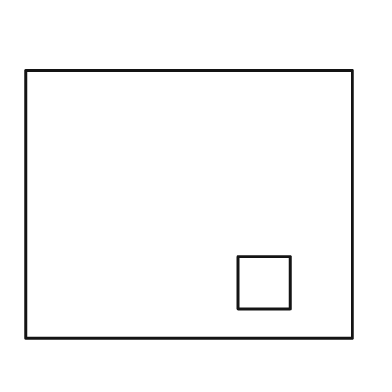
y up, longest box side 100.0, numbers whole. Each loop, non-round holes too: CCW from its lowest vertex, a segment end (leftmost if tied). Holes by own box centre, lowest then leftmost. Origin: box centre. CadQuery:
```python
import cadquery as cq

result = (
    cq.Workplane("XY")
    .moveTo(-50.0, -41.0)
    .lineTo(50.0, -41.0)
    .lineTo(50.0, 41.0)
    .lineTo(-50.0, 41.0)
    .close()
    .moveTo(15.0, -32.0)
    .lineTo(31.0, -32.0)
    .lineTo(31.0, -16.0)
    .lineTo(15.0, -16.0)
    .close()
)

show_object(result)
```